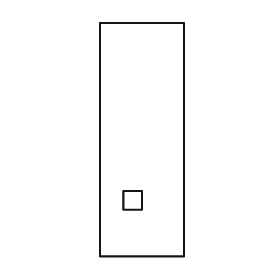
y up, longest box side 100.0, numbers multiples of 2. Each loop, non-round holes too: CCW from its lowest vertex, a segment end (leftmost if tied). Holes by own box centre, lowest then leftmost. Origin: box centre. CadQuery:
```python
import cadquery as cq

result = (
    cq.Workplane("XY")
    .moveTo(-18.0, -50.0)
    .lineTo(18.0, -50.0)
    .lineTo(18.0, 50.0)
    .lineTo(-18.0, 50.0)
    .close()
    .moveTo(-8.0, -30.0)
    .lineTo(0.0, -30.0)
    .lineTo(0.0, -22.0)
    .lineTo(-8.0, -22.0)
    .close()
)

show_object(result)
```